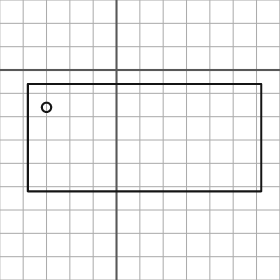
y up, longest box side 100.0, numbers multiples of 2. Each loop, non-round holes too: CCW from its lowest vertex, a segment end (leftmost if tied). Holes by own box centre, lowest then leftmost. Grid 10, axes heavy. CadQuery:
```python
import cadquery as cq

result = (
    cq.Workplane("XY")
    .moveTo(-38.0, -52.0)
    .lineTo(62.0, -52.0)
    .lineTo(62.0, -6.0)
    .lineTo(-38.0, -6.0)
    .close()
    .moveTo(-30.0, -16.0)
    .circle(2.0)
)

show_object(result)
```